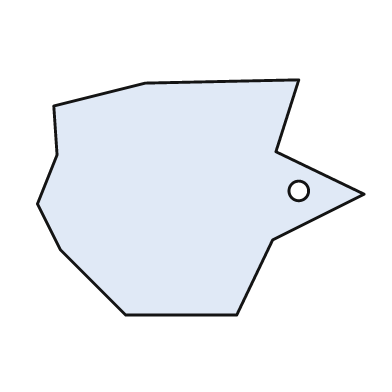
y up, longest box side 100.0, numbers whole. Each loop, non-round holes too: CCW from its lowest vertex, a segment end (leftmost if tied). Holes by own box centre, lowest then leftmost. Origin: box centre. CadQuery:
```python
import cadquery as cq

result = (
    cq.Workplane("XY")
    .moveTo(-23.0, -36.0)
    .lineTo(11.0, -36.0)
    .lineTo(22.0, -13.0)
    .lineTo(50.0, 1.0)
    .lineTo(23.0, 14.0)
    .lineTo(30.0, 36.0)
    .lineTo(-17.0, 35.0)
    .lineTo(-45.0, 28.0)
    .lineTo(-44.0, 13.0)
    .lineTo(-50.0, -2.0)
    .lineTo(-43.0, -16.0)
    .close()
    .moveTo(30.0, 2.0)
    .circle(3.0)
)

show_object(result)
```